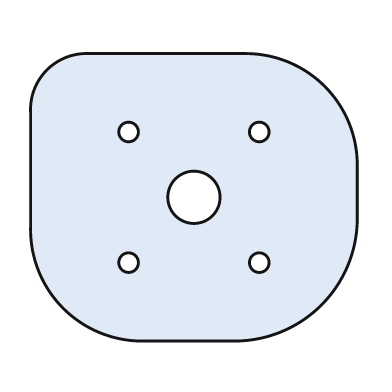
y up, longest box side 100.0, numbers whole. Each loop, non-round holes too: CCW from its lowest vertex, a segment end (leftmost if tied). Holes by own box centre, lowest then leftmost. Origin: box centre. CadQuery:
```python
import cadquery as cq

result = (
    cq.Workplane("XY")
    .moveTo(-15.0, -44.0)
    .lineTo(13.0, -44.0)
    .threePointArc((39.0, -33.0), (50.0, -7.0))
    .lineTo(50.0, 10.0)
    .threePointArc((40.0, 34.0), (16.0, 44.0))
    .lineTo(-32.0, 44.0)
    .threePointArc((-45.0, 39.0), (-50.0, 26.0))
    .lineTo(-50.0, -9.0)
    .threePointArc((-40.0, -34.0), (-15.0, -44.0))
    .close()
    .moveTo(-20.0, -20.0)
    .circle(3.0)
    .moveTo(20.0, -20.0)
    .circle(3.0)
    .moveTo(0.0, 0.0)
    .circle(8.0)
    .moveTo(-20.0, 20.0)
    .circle(3.0)
    .moveTo(20.0, 20.0)
    .circle(3.0)
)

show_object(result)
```